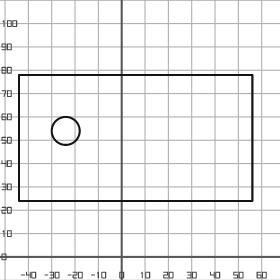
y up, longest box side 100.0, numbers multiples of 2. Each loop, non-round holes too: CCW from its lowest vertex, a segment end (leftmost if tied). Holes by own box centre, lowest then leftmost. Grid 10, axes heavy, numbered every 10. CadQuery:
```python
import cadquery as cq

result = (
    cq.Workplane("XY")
    .moveTo(-44.0, 24.0)
    .lineTo(56.0, 24.0)
    .lineTo(56.0, 78.0)
    .lineTo(-44.0, 78.0)
    .close()
    .moveTo(-24.0, 54.0)
    .circle(6.0)
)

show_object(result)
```